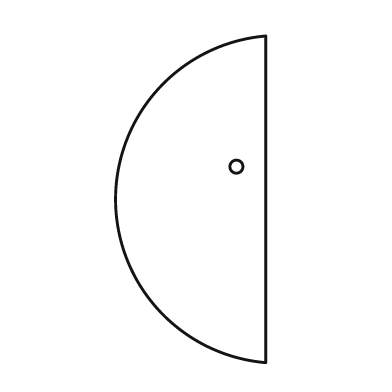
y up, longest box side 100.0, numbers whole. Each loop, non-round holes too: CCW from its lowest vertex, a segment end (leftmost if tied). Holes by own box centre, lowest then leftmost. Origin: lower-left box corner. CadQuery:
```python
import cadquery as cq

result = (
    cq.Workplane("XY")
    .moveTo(46.0, 0.0)
    .lineTo(46.0, 100.0)
    .threePointArc((0.0, 50.0), (46.0, 0.0))
    .close()
    .moveTo(37.0, 60.0)
    .circle(2.0)
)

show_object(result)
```